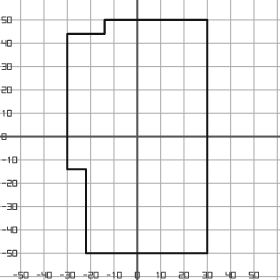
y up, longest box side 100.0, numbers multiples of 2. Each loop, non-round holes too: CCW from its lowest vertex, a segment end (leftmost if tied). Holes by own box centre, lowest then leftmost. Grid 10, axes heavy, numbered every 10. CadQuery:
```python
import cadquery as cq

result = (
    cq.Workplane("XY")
    .moveTo(-22.0, -50.0)
    .lineTo(30.0, -50.0)
    .lineTo(30.0, 50.0)
    .lineTo(-14.0, 50.0)
    .lineTo(-14.0, 44.0)
    .lineTo(-30.0, 44.0)
    .lineTo(-30.0, -14.0)
    .lineTo(-22.0, -14.0)
    .close()
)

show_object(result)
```